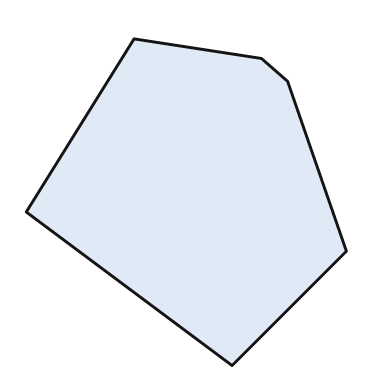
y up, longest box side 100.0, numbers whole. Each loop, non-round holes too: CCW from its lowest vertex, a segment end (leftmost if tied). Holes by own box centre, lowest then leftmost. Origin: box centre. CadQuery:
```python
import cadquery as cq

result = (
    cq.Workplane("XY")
    .moveTo(14.0, -50.0)
    .lineTo(49.0, -15.0)
    .lineTo(31.0, 37.0)
    .lineTo(23.0, 44.0)
    .lineTo(-16.0, 50.0)
    .lineTo(-49.0, -3.0)
    .close()
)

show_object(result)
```